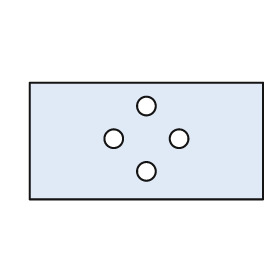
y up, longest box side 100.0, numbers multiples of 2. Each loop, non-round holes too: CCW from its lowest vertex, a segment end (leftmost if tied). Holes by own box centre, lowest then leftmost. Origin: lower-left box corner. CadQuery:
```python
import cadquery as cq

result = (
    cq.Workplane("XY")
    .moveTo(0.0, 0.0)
    .lineTo(100.0, 0.0)
    .lineTo(100.0, 50.0)
    .lineTo(0.0, 50.0)
    .close()
    .moveTo(50.0, 12.0)
    .circle(4.0)
    .moveTo(36.0, 26.0)
    .circle(4.0)
    .moveTo(64.0, 26.0)
    .circle(4.0)
    .moveTo(50.0, 40.0)
    .circle(4.0)
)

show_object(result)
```